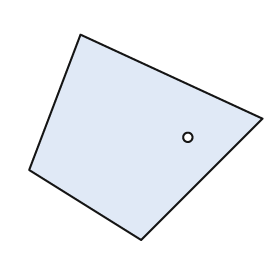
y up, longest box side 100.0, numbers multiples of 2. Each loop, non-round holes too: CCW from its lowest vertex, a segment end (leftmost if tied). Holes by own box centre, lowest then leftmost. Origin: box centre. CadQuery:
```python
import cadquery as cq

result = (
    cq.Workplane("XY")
    .moveTo(-2.0, -44.0)
    .lineTo(50.0, 8.0)
    .lineTo(-28.0, 44.0)
    .lineTo(-50.0, -14.0)
    .close()
    .moveTo(18.0, 0.0)
    .circle(2.0)
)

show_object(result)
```